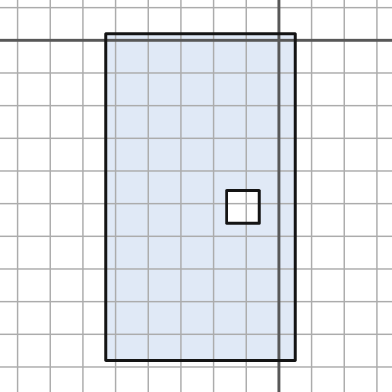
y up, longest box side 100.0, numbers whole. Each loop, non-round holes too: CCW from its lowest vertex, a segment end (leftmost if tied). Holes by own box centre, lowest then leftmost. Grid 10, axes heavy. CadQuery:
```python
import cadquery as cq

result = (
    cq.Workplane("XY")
    .moveTo(-53.0, -98.0)
    .lineTo(5.0, -98.0)
    .lineTo(5.0, 2.0)
    .lineTo(-53.0, 2.0)
    .close()
    .moveTo(-16.0, -56.0)
    .lineTo(-6.0, -56.0)
    .lineTo(-6.0, -46.0)
    .lineTo(-16.0, -46.0)
    .close()
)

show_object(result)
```